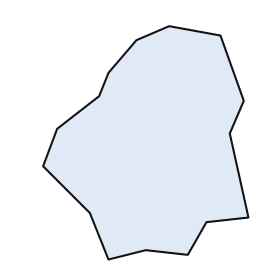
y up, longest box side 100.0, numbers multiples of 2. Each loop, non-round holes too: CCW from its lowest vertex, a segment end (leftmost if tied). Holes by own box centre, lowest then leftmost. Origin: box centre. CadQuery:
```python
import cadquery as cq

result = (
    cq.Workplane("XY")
    .moveTo(-16.0, -50.0)
    .lineTo(0.0, -46.0)
    .lineTo(18.0, -48.0)
    .lineTo(26.0, -34.0)
    .lineTo(44.0, -32.0)
    .lineTo(36.0, 4.0)
    .lineTo(42.0, 18.0)
    .lineTo(32.0, 46.0)
    .lineTo(10.0, 50.0)
    .lineTo(-4.0, 44.0)
    .lineTo(-16.0, 30.0)
    .lineTo(-20.0, 20.0)
    .lineTo(-38.0, 6.0)
    .lineTo(-44.0, -10.0)
    .lineTo(-24.0, -30.0)
    .close()
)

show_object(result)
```